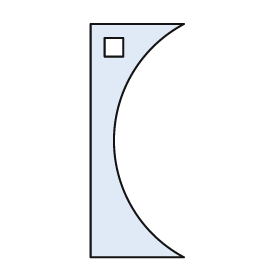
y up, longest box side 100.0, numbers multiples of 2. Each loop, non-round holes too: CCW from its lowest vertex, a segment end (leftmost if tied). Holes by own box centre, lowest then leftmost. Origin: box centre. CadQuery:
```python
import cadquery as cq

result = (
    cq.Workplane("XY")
    .moveTo(-20.0, -50.0)
    .lineTo(20.0, -50.0)
    .threePointArc((-10.0, 0.0), (20.0, 50.0))
    .lineTo(-20.0, 50.0)
    .close()
    .moveTo(-14.0, 36.0)
    .lineTo(-6.0, 36.0)
    .lineTo(-6.0, 44.0)
    .lineTo(-14.0, 44.0)
    .close()
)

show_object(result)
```